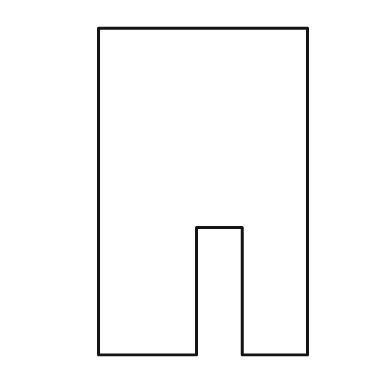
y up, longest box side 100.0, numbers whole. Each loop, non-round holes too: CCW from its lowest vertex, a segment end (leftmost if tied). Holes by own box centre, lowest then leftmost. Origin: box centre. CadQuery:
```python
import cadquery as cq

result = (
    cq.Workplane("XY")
    .moveTo(-32.0, -50.0)
    .lineTo(-2.0, -50.0)
    .lineTo(-2.0, -11.0)
    .lineTo(12.0, -11.0)
    .lineTo(12.0, -50.0)
    .lineTo(32.0, -50.0)
    .lineTo(32.0, 50.0)
    .lineTo(-32.0, 50.0)
    .close()
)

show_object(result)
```